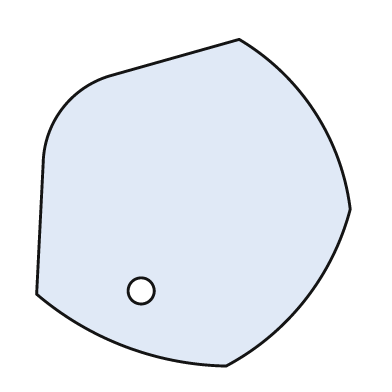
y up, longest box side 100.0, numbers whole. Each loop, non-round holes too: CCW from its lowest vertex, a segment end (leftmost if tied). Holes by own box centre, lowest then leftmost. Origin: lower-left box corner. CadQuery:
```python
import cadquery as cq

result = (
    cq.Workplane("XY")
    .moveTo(58.0, 0.0)
    .threePointArc((82.0, 20.0), (96.0, 48.0))
    .threePointArc((85.0, 78.0), (62.0, 100.0))
    .lineTo(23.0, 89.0)
    .threePointArc((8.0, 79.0), (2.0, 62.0))
    .lineTo(0.0, 22.0)
    .threePointArc((27.0, 6.0), (58.0, 0.0))
    .close()
    .moveTo(32.0, 23.0)
    .circle(4.0)
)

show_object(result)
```